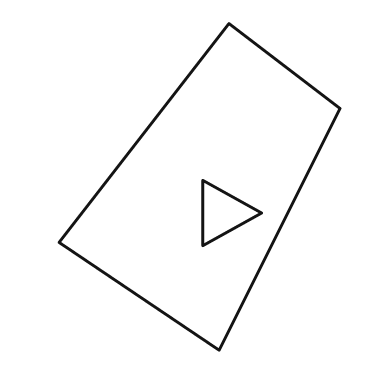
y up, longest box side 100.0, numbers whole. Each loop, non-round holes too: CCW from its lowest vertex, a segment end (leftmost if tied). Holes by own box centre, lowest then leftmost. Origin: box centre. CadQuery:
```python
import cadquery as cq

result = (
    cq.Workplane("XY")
    .moveTo(6.0, -50.0)
    .lineTo(43.0, 24.0)
    .lineTo(9.0, 50.0)
    .lineTo(-43.0, -17.0)
    .close()
    .moveTo(1.0, -18.0)
    .lineTo(19.0, -8.0)
    .lineTo(1.0, 2.0)
    .close()
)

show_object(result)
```